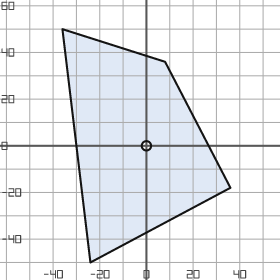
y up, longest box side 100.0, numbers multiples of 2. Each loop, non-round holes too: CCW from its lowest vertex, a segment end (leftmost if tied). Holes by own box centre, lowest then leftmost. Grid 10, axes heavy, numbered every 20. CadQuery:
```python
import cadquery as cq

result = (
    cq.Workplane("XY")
    .moveTo(-24.0, -50.0)
    .lineTo(36.0, -18.0)
    .lineTo(8.0, 36.0)
    .lineTo(-36.0, 50.0)
    .close()
    .moveTo(0.0, 0.0)
    .circle(2.0)
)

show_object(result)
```